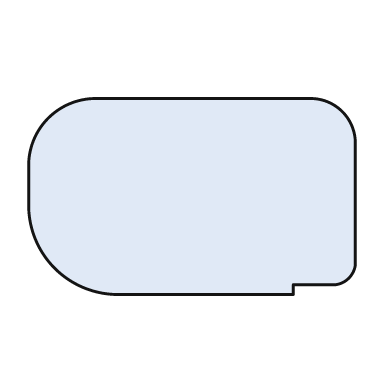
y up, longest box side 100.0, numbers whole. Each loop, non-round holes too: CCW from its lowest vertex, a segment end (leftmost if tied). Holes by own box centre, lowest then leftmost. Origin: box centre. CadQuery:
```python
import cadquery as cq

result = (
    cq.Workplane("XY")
    .moveTo(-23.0, -30.0)
    .lineTo(31.0, -30.0)
    .lineTo(31.0, -27.0)
    .lineTo(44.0, -27.0)
    .threePointArc((48.0, -25.0), (50.0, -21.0))
    .lineTo(50.0, 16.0)
    .threePointArc((46.0, 26.0), (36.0, 30.0))
    .lineTo(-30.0, 30.0)
    .threePointArc((-44.0, 24.0), (-50.0, 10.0))
    .lineTo(-50.0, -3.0)
    .threePointArc((-42.0, -22.0), (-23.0, -30.0))
    .close()
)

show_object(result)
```